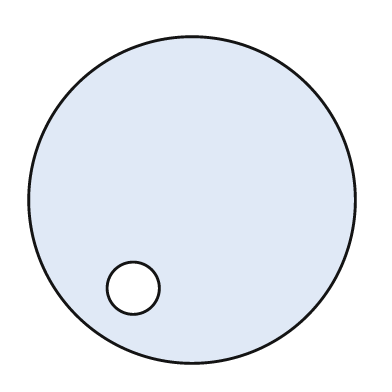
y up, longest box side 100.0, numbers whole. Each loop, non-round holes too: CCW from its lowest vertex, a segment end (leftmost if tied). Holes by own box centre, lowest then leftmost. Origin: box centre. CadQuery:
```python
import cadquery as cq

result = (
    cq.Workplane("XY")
    .moveTo(0.0, 0.0)
    .circle(50.0)
    .moveTo(-18.0, -27.0)
    .circle(8.0)
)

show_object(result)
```